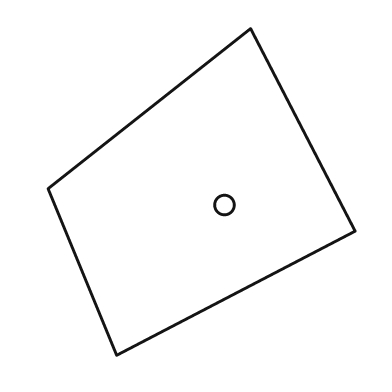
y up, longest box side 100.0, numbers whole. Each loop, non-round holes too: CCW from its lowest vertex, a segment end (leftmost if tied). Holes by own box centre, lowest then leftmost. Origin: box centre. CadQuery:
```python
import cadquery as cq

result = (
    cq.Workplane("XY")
    .moveTo(-26.0, -50.0)
    .lineTo(47.0, -12.0)
    .lineTo(15.0, 50.0)
    .lineTo(-47.0, 1.0)
    .close()
    .moveTo(7.0, -4.0)
    .circle(3.0)
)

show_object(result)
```